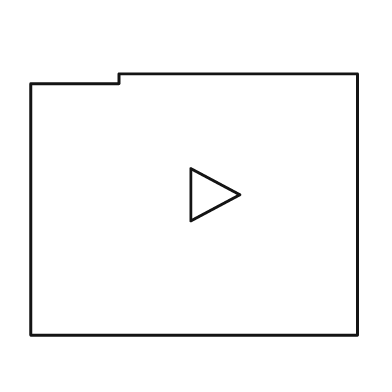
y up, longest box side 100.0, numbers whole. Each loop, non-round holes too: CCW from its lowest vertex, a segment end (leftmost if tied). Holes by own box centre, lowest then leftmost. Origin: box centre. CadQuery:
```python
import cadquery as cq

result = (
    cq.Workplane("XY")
    .moveTo(-50.0, -40.0)
    .lineTo(50.0, -40.0)
    .lineTo(50.0, 40.0)
    .lineTo(-23.0, 40.0)
    .lineTo(-23.0, 37.0)
    .lineTo(-50.0, 37.0)
    .close()
    .moveTo(-1.0, -5.0)
    .lineTo(14.0, 3.0)
    .lineTo(-1.0, 11.0)
    .close()
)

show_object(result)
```